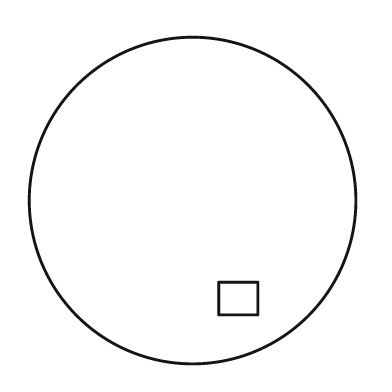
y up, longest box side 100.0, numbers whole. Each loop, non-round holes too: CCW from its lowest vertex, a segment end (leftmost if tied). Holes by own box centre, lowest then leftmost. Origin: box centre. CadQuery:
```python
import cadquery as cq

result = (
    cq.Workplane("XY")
    .moveTo(0.0, 0.0)
    .circle(50.0)
    .moveTo(8.0, -35.0)
    .lineTo(20.0, -35.0)
    .lineTo(20.0, -25.0)
    .lineTo(8.0, -25.0)
    .close()
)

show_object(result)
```